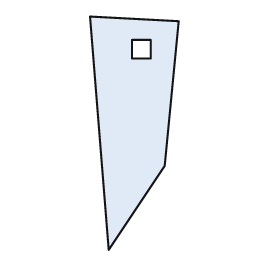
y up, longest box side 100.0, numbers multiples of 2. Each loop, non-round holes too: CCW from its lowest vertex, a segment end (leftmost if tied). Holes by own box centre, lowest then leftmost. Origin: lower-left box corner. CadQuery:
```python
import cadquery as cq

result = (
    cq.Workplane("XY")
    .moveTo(8.0, 0.0)
    .lineTo(32.0, 36.0)
    .lineTo(38.0, 98.0)
    .lineTo(0.0, 100.0)
    .close()
    .moveTo(18.0, 82.0)
    .lineTo(26.0, 82.0)
    .lineTo(26.0, 90.0)
    .lineTo(18.0, 90.0)
    .close()
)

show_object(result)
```